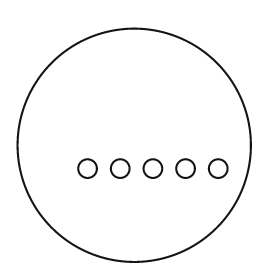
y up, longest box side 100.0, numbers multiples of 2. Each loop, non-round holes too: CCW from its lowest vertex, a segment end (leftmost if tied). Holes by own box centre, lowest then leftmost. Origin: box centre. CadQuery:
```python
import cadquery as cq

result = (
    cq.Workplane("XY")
    .moveTo(0.0, 0.0)
    .circle(50.0)
    .moveTo(-20.0, -10.0)
    .circle(4.0)
    .moveTo(-6.0, -10.0)
    .circle(4.0)
    .moveTo(8.0, -10.0)
    .circle(4.0)
    .moveTo(22.0, -10.0)
    .circle(4.0)
    .moveTo(36.0, -10.0)
    .circle(4.0)
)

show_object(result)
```